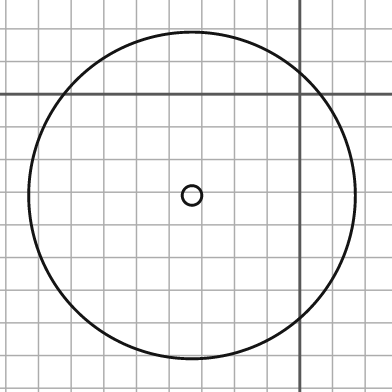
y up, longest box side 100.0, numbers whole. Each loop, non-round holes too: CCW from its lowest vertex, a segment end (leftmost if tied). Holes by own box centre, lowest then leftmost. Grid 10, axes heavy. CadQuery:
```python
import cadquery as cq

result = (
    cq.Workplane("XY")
    .moveTo(-33.0, -31.0)
    .circle(50.0)
    .moveTo(-33.0, -31.0)
    .circle(3.0)
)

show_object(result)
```